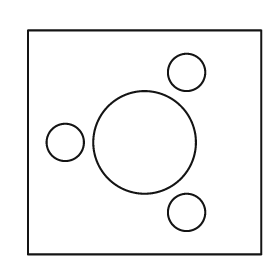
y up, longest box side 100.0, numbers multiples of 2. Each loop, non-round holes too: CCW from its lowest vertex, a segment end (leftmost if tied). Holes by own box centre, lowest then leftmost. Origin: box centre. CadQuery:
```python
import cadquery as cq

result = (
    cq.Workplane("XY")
    .moveTo(-50.0, -48.0)
    .lineTo(50.0, -48.0)
    .lineTo(50.0, 48.0)
    .lineTo(-50.0, 48.0)
    .close()
    .moveTo(18.0, -30.0)
    .circle(8.0)
    .moveTo(-34.0, 0.0)
    .circle(8.0)
    .moveTo(0.0, 0.0)
    .circle(22.0)
    .moveTo(18.0, 30.0)
    .circle(8.0)
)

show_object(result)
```